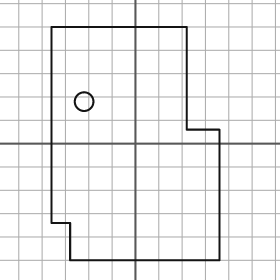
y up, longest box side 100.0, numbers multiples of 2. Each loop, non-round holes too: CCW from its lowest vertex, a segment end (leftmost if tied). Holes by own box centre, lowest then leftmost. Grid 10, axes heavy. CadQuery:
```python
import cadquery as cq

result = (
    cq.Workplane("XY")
    .moveTo(-28.0, -50.0)
    .lineTo(36.0, -50.0)
    .lineTo(36.0, 6.0)
    .lineTo(22.0, 6.0)
    .lineTo(22.0, 50.0)
    .lineTo(-36.0, 50.0)
    .lineTo(-36.0, -34.0)
    .lineTo(-28.0, -34.0)
    .close()
    .moveTo(-22.0, 18.0)
    .circle(4.0)
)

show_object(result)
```